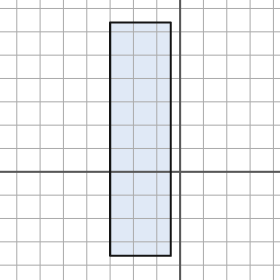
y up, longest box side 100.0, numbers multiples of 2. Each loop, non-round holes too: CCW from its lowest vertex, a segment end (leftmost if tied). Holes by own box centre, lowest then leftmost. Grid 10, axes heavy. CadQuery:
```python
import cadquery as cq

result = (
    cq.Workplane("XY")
    .moveTo(-30.0, -36.0)
    .lineTo(-4.0, -36.0)
    .lineTo(-4.0, 64.0)
    .lineTo(-30.0, 64.0)
    .close()
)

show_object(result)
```